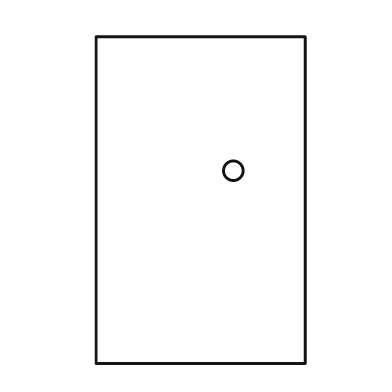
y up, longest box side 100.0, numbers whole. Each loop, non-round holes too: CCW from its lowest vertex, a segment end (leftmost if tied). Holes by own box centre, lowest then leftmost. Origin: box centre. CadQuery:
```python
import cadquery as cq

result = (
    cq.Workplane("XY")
    .moveTo(-32.0, -50.0)
    .lineTo(32.0, -50.0)
    .lineTo(32.0, 50.0)
    .lineTo(-32.0, 50.0)
    .close()
    .moveTo(10.0, 9.0)
    .circle(3.0)
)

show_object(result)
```